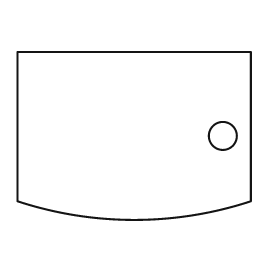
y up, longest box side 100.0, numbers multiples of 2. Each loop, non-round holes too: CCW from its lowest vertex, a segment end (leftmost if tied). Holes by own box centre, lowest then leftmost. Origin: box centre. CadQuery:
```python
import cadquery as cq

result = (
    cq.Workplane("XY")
    .moveTo(-50.0, -28.0)
    .threePointArc((0.0, -36.0), (50.0, -28.0))
    .lineTo(50.0, 36.0)
    .lineTo(-50.0, 36.0)
    .close()
    .moveTo(38.0, 0.0)
    .circle(6.0)
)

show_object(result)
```